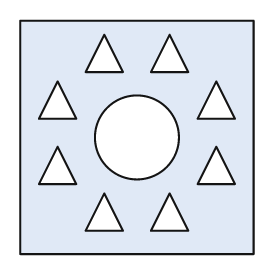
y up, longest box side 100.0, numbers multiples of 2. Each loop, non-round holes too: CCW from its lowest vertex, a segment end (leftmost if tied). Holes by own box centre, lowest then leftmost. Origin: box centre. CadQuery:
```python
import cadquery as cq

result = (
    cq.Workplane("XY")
    .moveTo(-50.0, -50.0)
    .lineTo(50.0, -50.0)
    .lineTo(50.0, 50.0)
    .lineTo(-50.0, 50.0)
    .close()
    .moveTo(-22.0, -40.0)
    .lineTo(-6.0, -40.0)
    .lineTo(-14.0, -24.0)
    .close()
    .moveTo(6.0, -40.0)
    .lineTo(22.0, -40.0)
    .lineTo(14.0, -24.0)
    .close()
    .moveTo(-42.0, -20.0)
    .lineTo(-26.0, -20.0)
    .lineTo(-34.0, -4.0)
    .close()
    .moveTo(26.0, -20.0)
    .lineTo(42.0, -20.0)
    .lineTo(34.0, -4.0)
    .close()
    .moveTo(0.0, 0.0)
    .circle(18.0)
    .moveTo(-42.0, 8.0)
    .lineTo(-26.0, 8.0)
    .lineTo(-34.0, 24.0)
    .close()
    .moveTo(26.0, 8.0)
    .lineTo(42.0, 8.0)
    .lineTo(34.0, 24.0)
    .close()
    .moveTo(-22.0, 28.0)
    .lineTo(-6.0, 28.0)
    .lineTo(-14.0, 44.0)
    .close()
    .moveTo(6.0, 28.0)
    .lineTo(22.0, 28.0)
    .lineTo(14.0, 44.0)
    .close()
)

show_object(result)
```